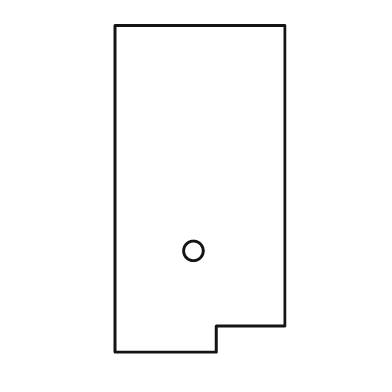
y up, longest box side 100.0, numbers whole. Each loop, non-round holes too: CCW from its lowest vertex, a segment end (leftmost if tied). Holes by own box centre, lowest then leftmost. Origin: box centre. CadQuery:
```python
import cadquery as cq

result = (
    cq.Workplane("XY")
    .moveTo(-26.0, -50.0)
    .lineTo(5.0, -50.0)
    .lineTo(5.0, -42.0)
    .lineTo(26.0, -42.0)
    .lineTo(26.0, 50.0)
    .lineTo(-26.0, 50.0)
    .close()
    .moveTo(-2.0, -19.0)
    .circle(3.0)
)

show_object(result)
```